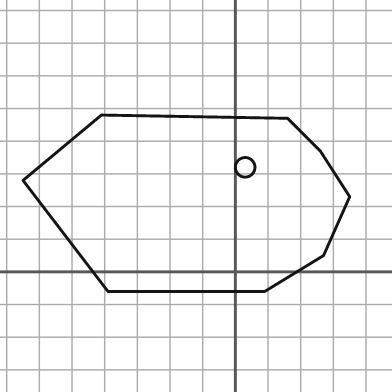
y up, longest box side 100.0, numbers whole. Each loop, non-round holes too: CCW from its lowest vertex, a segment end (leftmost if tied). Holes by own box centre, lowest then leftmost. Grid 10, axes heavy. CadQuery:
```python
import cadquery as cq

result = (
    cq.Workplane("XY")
    .moveTo(-39.0, -6.0)
    .lineTo(9.0, -6.0)
    .lineTo(27.0, 5.0)
    .lineTo(35.0, 23.0)
    .lineTo(26.0, 37.0)
    .lineTo(16.0, 47.0)
    .lineTo(-41.0, 48.0)
    .lineTo(-65.0, 28.0)
    .close()
    .moveTo(3.0, 32.0)
    .circle(3.0)
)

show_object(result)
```